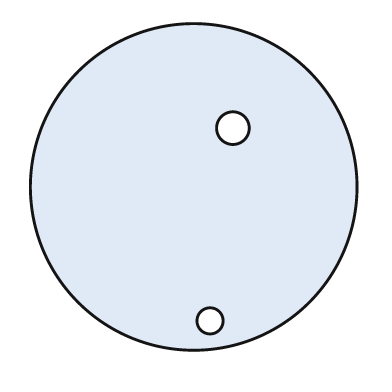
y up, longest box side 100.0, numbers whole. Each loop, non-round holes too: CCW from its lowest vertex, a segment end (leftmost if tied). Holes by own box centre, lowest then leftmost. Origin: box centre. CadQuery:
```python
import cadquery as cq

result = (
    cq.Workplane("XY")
    .moveTo(0.0, 0.0)
    .circle(50.0)
    .moveTo(5.0, -41.0)
    .circle(4.0)
    .moveTo(12.0, 18.0)
    .circle(5.0)
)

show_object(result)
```